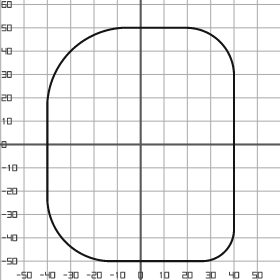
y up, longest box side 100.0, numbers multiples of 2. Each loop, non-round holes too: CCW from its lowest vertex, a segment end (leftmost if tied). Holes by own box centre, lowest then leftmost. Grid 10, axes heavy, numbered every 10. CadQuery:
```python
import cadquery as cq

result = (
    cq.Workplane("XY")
    .moveTo(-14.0, -50.0)
    .lineTo(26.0, -50.0)
    .threePointArc((36.0, -46.0), (40.0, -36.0))
    .lineTo(40.0, 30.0)
    .threePointArc((34.0, 44.0), (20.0, 50.0))
    .lineTo(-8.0, 50.0)
    .threePointArc((-30.0, 40.0), (-40.0, 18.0))
    .lineTo(-40.0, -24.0)
    .threePointArc((-32.0, -42.0), (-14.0, -50.0))
    .close()
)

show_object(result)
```